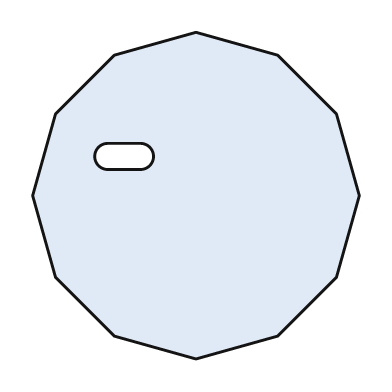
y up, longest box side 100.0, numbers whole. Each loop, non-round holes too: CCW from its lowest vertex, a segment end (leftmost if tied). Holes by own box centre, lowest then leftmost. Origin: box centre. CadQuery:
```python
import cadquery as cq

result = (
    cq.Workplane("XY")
    .moveTo(0.0, -50.0)
    .lineTo(25.0, -43.0)
    .lineTo(43.0, -25.0)
    .lineTo(50.0, 0.0)
    .lineTo(43.0, 25.0)
    .lineTo(25.0, 43.0)
    .lineTo(0.0, 50.0)
    .lineTo(-25.0, 43.0)
    .lineTo(-43.0, 25.0)
    .lineTo(-50.0, 0.0)
    .lineTo(-43.0, -25.0)
    .lineTo(-25.0, -43.0)
    .close()
    .moveTo(-27.0, 8.0)
    .lineTo(-17.0, 8.0)
    .threePointArc((-13.0, 12.0), (-17.0, 16.0))
    .lineTo(-27.0, 16.0)
    .threePointArc((-31.0, 12.0), (-27.0, 8.0))
    .close()
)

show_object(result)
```